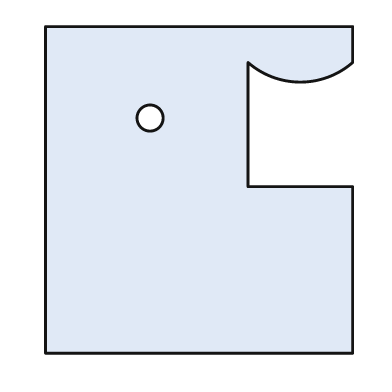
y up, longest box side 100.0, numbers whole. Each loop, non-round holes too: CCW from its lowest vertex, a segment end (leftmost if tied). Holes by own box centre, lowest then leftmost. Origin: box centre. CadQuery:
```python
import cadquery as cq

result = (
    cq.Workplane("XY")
    .moveTo(-47.0, -50.0)
    .lineTo(47.0, -50.0)
    .lineTo(47.0, 1.0)
    .lineTo(15.0, 1.0)
    .lineTo(15.0, 39.0)
    .threePointArc((31.0, 33.0), (47.0, 39.0))
    .lineTo(47.0, 50.0)
    .lineTo(-47.0, 50.0)
    .close()
    .moveTo(-15.0, 22.0)
    .circle(4.0)
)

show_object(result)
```